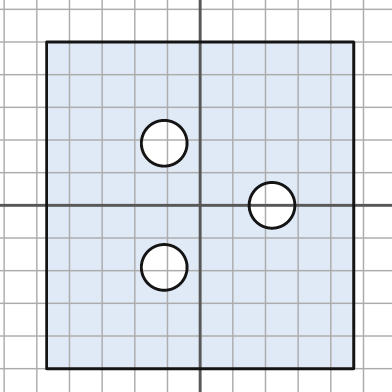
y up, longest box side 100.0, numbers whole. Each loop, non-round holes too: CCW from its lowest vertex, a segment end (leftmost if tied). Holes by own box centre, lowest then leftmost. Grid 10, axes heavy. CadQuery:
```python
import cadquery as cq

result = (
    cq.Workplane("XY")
    .moveTo(-47.0, -50.0)
    .lineTo(47.0, -50.0)
    .lineTo(47.0, 50.0)
    .lineTo(-47.0, 50.0)
    .close()
    .moveTo(-11.0, -19.0)
    .circle(7.0)
    .moveTo(22.0, 0.0)
    .circle(7.0)
    .moveTo(-11.0, 19.0)
    .circle(7.0)
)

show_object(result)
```